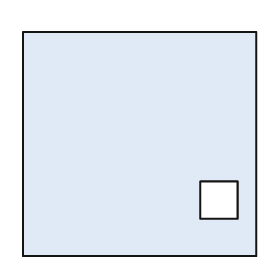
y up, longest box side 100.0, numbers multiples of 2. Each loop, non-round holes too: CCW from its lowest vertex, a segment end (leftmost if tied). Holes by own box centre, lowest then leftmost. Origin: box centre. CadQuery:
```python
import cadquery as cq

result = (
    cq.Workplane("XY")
    .moveTo(-50.0, -48.0)
    .lineTo(50.0, -48.0)
    .lineTo(50.0, 48.0)
    .lineTo(-50.0, 48.0)
    .close()
    .moveTo(26.0, -32.0)
    .lineTo(42.0, -32.0)
    .lineTo(42.0, -16.0)
    .lineTo(26.0, -16.0)
    .close()
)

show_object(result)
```